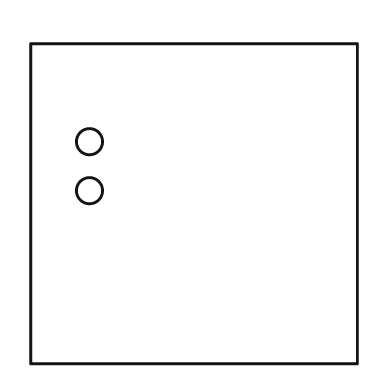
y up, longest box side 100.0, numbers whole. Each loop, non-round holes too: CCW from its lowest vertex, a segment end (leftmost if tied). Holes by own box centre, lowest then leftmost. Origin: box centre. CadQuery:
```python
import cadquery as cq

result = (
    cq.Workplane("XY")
    .moveTo(-50.0, -49.0)
    .lineTo(50.0, -49.0)
    .lineTo(50.0, 49.0)
    .lineTo(-50.0, 49.0)
    .close()
    .moveTo(-32.0, 4.0)
    .circle(4.0)
    .moveTo(-32.0, 19.0)
    .circle(4.0)
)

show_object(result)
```